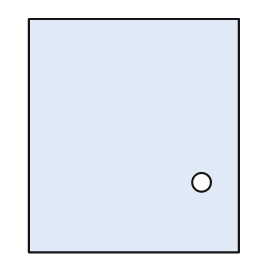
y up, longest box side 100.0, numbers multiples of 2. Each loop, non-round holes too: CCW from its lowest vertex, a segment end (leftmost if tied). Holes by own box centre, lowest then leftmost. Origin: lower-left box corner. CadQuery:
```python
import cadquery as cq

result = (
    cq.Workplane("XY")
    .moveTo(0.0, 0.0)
    .lineTo(90.0, 0.0)
    .lineTo(90.0, 100.0)
    .lineTo(0.0, 100.0)
    .close()
    .moveTo(74.0, 30.0)
    .circle(4.0)
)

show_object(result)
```